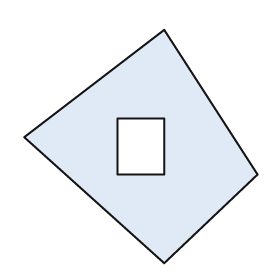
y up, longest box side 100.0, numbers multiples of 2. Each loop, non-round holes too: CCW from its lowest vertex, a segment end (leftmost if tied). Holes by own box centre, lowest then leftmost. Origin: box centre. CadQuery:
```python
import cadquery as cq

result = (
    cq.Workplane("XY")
    .moveTo(10.0, -50.0)
    .lineTo(50.0, -12.0)
    .lineTo(10.0, 50.0)
    .lineTo(-50.0, 4.0)
    .close()
    .moveTo(-10.0, -12.0)
    .lineTo(10.0, -12.0)
    .lineTo(10.0, 12.0)
    .lineTo(-10.0, 12.0)
    .close()
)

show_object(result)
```